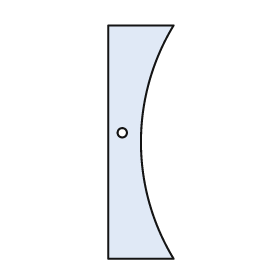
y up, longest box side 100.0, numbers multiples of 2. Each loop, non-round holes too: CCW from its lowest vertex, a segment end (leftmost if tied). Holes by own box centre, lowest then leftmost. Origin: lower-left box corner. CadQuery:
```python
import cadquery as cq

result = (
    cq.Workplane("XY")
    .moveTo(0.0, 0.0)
    .lineTo(28.0, 0.0)
    .threePointArc((14.0, 50.0), (28.0, 100.0))
    .lineTo(0.0, 100.0)
    .close()
    .moveTo(6.0, 54.0)
    .circle(2.0)
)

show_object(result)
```